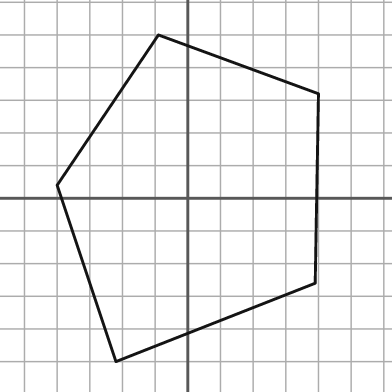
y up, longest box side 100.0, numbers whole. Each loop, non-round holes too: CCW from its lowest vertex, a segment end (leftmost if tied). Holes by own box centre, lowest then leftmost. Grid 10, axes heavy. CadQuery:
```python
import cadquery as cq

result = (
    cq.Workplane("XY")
    .moveTo(-22.0, -50.0)
    .lineTo(39.0, -26.0)
    .lineTo(40.0, 32.0)
    .lineTo(-9.0, 50.0)
    .lineTo(-40.0, 4.0)
    .close()
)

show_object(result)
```